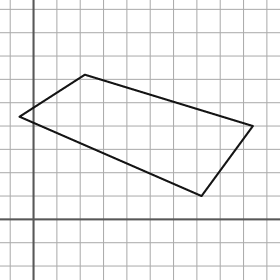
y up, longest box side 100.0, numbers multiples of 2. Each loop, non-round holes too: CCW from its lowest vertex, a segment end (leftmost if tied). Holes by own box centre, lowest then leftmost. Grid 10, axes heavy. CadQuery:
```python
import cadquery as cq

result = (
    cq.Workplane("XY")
    .moveTo(72.0, 10.0)
    .lineTo(94.0, 40.0)
    .lineTo(22.0, 62.0)
    .lineTo(-6.0, 44.0)
    .close()
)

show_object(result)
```